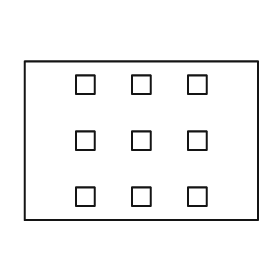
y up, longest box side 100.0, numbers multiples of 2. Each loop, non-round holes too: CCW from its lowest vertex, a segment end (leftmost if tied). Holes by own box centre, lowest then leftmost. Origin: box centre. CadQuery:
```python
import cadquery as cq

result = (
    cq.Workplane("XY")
    .moveTo(-50.0, -34.0)
    .lineTo(50.0, -34.0)
    .lineTo(50.0, 34.0)
    .lineTo(-50.0, 34.0)
    .close()
    .moveTo(-28.0, -28.0)
    .lineTo(-20.0, -28.0)
    .lineTo(-20.0, -20.0)
    .lineTo(-28.0, -20.0)
    .close()
    .moveTo(-4.0, -28.0)
    .lineTo(4.0, -28.0)
    .lineTo(4.0, -20.0)
    .lineTo(-4.0, -20.0)
    .close()
    .moveTo(20.0, -28.0)
    .lineTo(28.0, -28.0)
    .lineTo(28.0, -20.0)
    .lineTo(20.0, -20.0)
    .close()
    .moveTo(-28.0, -4.0)
    .lineTo(-20.0, -4.0)
    .lineTo(-20.0, 4.0)
    .lineTo(-28.0, 4.0)
    .close()
    .moveTo(-4.0, -4.0)
    .lineTo(4.0, -4.0)
    .lineTo(4.0, 4.0)
    .lineTo(-4.0, 4.0)
    .close()
    .moveTo(20.0, -4.0)
    .lineTo(28.0, -4.0)
    .lineTo(28.0, 4.0)
    .lineTo(20.0, 4.0)
    .close()
    .moveTo(-28.0, 20.0)
    .lineTo(-20.0, 20.0)
    .lineTo(-20.0, 28.0)
    .lineTo(-28.0, 28.0)
    .close()
    .moveTo(-4.0, 20.0)
    .lineTo(4.0, 20.0)
    .lineTo(4.0, 28.0)
    .lineTo(-4.0, 28.0)
    .close()
    .moveTo(20.0, 20.0)
    .lineTo(28.0, 20.0)
    .lineTo(28.0, 28.0)
    .lineTo(20.0, 28.0)
    .close()
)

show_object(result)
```